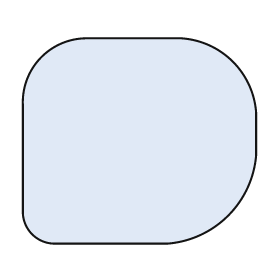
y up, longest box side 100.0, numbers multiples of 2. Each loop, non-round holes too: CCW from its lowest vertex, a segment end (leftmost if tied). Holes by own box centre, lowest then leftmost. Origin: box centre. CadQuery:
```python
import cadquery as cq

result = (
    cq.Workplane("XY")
    .moveTo(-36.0, -44.0)
    .lineTo(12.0, -44.0)
    .threePointArc((38.0, -32.0), (50.0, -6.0))
    .lineTo(50.0, 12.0)
    .threePointArc((40.0, 34.0), (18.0, 44.0))
    .lineTo(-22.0, 44.0)
    .threePointArc((-42.0, 36.0), (-50.0, 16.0))
    .lineTo(-50.0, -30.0)
    .threePointArc((-46.0, -40.0), (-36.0, -44.0))
    .close()
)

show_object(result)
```